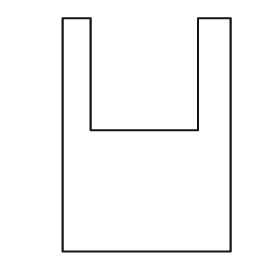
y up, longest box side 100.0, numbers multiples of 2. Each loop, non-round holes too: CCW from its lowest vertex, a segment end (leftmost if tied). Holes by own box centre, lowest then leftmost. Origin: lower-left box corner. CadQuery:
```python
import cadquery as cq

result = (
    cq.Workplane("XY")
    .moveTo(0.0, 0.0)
    .lineTo(72.0, 0.0)
    .lineTo(72.0, 100.0)
    .lineTo(58.0, 100.0)
    .lineTo(58.0, 52.0)
    .lineTo(12.0, 52.0)
    .lineTo(12.0, 100.0)
    .lineTo(0.0, 100.0)
    .close()
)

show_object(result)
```